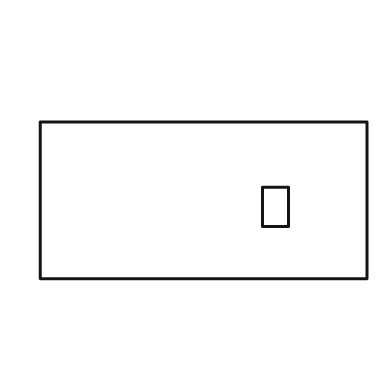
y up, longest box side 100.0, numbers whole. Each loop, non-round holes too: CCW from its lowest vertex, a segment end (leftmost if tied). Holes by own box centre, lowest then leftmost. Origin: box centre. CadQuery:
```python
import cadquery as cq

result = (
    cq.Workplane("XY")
    .moveTo(-50.0, -24.0)
    .lineTo(50.0, -24.0)
    .lineTo(50.0, 24.0)
    .lineTo(-50.0, 24.0)
    .close()
    .moveTo(18.0, -8.0)
    .lineTo(26.0, -8.0)
    .lineTo(26.0, 4.0)
    .lineTo(18.0, 4.0)
    .close()
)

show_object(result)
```